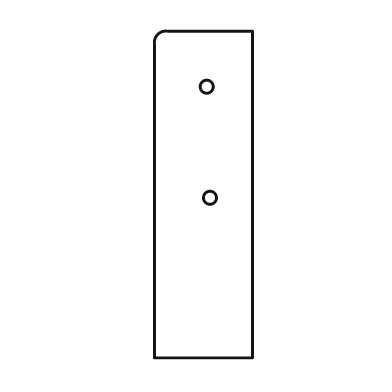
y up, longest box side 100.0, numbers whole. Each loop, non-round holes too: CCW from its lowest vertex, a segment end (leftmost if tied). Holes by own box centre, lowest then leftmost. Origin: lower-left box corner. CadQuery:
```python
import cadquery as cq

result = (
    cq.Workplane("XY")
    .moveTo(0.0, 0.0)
    .lineTo(30.0, 0.0)
    .lineTo(30.0, 100.0)
    .lineTo(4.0, 100.0)
    .threePointArc((1.0, 99.0), (0.0, 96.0))
    .close()
    .moveTo(17.0, 49.0)
    .circle(2.0)
    .moveTo(16.0, 83.0)
    .circle(2.0)
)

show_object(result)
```